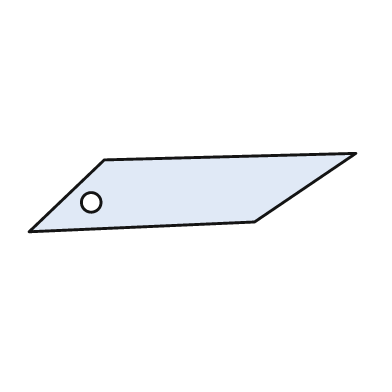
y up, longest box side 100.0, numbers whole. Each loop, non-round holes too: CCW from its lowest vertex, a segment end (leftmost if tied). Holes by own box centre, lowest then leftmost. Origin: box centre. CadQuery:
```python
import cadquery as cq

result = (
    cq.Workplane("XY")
    .moveTo(-50.0, -12.0)
    .lineTo(19.0, -9.0)
    .lineTo(50.0, 12.0)
    .lineTo(-27.0, 10.0)
    .close()
    .moveTo(-31.0, -3.0)
    .circle(3.0)
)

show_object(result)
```